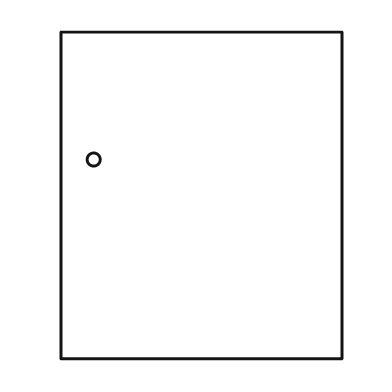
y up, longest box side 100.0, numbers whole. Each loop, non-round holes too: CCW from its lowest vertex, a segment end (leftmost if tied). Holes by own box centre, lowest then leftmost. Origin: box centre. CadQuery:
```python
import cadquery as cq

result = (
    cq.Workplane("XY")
    .moveTo(-43.0, -50.0)
    .lineTo(43.0, -50.0)
    .lineTo(43.0, 50.0)
    .lineTo(-43.0, 50.0)
    .close()
    .moveTo(-33.0, 11.0)
    .circle(2.0)
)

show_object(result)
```